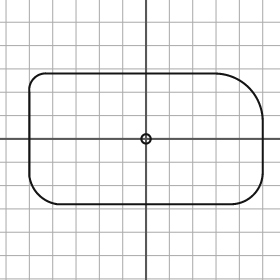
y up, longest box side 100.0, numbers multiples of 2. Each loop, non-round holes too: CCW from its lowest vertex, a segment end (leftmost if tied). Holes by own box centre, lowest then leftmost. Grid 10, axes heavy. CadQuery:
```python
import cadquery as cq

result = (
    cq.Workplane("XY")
    .moveTo(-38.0, -28.0)
    .lineTo(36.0, -28.0)
    .threePointArc((46.0, -24.0), (50.0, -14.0))
    .lineTo(50.0, 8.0)
    .threePointArc((44.0, 22.0), (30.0, 28.0))
    .lineTo(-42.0, 28.0)
    .threePointArc((-48.0, 26.0), (-50.0, 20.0))
    .lineTo(-50.0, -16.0)
    .threePointArc((-46.0, -24.0), (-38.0, -28.0))
    .close()
    .moveTo(0.0, 0.0)
    .circle(2.0)
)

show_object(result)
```